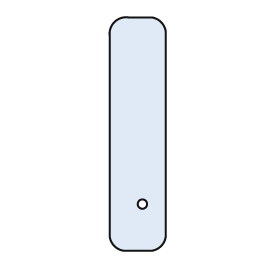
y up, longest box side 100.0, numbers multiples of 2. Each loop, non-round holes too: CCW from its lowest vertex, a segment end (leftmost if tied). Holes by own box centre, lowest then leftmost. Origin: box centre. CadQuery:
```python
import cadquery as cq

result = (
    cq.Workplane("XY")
    .moveTo(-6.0, -50.0)
    .lineTo(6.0, -50.0)
    .threePointArc((10.0, -48.0), (12.0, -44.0))
    .lineTo(12.0, 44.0)
    .threePointArc((10.0, 48.0), (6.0, 50.0))
    .lineTo(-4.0, 50.0)
    .threePointArc((-10.0, 48.0), (-12.0, 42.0))
    .lineTo(-12.0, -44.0)
    .threePointArc((-10.0, -48.0), (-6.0, -50.0))
    .close()
    .moveTo(2.0, -30.0)
    .circle(2.0)
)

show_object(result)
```